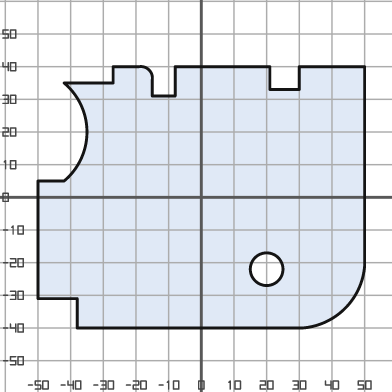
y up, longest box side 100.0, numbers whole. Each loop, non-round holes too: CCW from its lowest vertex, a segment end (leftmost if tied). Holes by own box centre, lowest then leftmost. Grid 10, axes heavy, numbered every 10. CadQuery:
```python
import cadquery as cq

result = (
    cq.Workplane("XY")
    .moveTo(-38.0, -40.0)
    .lineTo(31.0, -40.0)
    .threePointArc((44.0, -34.0), (50.0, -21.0))
    .lineTo(50.0, 40.0)
    .lineTo(30.0, 40.0)
    .lineTo(30.0, 33.0)
    .lineTo(21.0, 33.0)
    .lineTo(21.0, 40.0)
    .lineTo(-8.0, 40.0)
    .lineTo(-8.0, 31.0)
    .lineTo(-15.0, 31.0)
    .lineTo(-15.0, 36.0)
    .threePointArc((-16.0, 39.0), (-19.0, 40.0))
    .lineTo(-27.0, 40.0)
    .lineTo(-27.0, 35.0)
    .lineTo(-42.0, 35.0)
    .threePointArc((-35.0, 20.0), (-42.0, 5.0))
    .lineTo(-50.0, 5.0)
    .lineTo(-50.0, -31.0)
    .lineTo(-38.0, -31.0)
    .close()
    .moveTo(20.0, -22.0)
    .circle(5.0)
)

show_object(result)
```